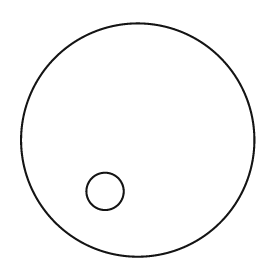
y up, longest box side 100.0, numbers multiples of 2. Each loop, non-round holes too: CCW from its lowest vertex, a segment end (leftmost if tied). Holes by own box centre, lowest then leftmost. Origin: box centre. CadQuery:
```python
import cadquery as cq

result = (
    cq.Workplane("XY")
    .moveTo(0.0, 0.0)
    .circle(50.0)
    .moveTo(-14.0, -22.0)
    .circle(8.0)
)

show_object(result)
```